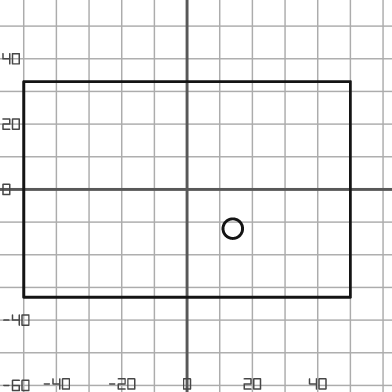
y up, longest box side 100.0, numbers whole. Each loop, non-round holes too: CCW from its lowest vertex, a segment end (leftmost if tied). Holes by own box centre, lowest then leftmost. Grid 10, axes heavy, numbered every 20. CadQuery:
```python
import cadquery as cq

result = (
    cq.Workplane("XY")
    .moveTo(-50.0, -33.0)
    .lineTo(50.0, -33.0)
    .lineTo(50.0, 33.0)
    .lineTo(-50.0, 33.0)
    .close()
    .moveTo(14.0, -12.0)
    .circle(3.0)
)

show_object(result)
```